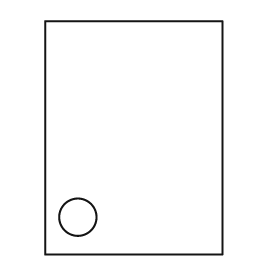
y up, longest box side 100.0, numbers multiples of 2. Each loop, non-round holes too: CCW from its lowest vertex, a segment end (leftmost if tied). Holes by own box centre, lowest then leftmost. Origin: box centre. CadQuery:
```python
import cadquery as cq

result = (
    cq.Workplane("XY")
    .moveTo(-38.0, -50.0)
    .lineTo(38.0, -50.0)
    .lineTo(38.0, 50.0)
    .lineTo(-38.0, 50.0)
    .close()
    .moveTo(-24.0, -34.0)
    .circle(8.0)
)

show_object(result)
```